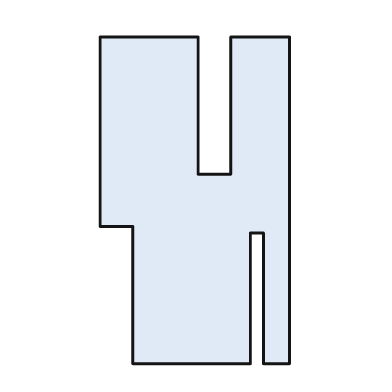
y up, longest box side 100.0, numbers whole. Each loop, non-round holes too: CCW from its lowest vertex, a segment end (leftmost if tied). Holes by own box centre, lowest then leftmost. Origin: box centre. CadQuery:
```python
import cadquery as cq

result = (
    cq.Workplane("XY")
    .moveTo(-19.0, -50.0)
    .lineTo(17.0, -50.0)
    .lineTo(17.0, -10.0)
    .lineTo(21.0, -10.0)
    .lineTo(21.0, -50.0)
    .lineTo(29.0, -50.0)
    .lineTo(29.0, 50.0)
    .lineTo(11.0, 50.0)
    .lineTo(11.0, 8.0)
    .lineTo(1.0, 8.0)
    .lineTo(1.0, 50.0)
    .lineTo(-29.0, 50.0)
    .lineTo(-29.0, -8.0)
    .lineTo(-19.0, -8.0)
    .close()
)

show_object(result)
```